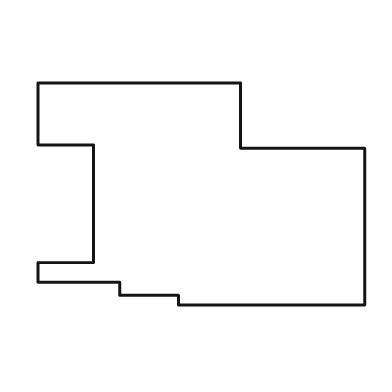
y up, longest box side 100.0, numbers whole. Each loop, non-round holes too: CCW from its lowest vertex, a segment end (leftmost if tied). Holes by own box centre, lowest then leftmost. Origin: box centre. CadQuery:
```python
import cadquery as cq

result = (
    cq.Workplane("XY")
    .moveTo(-7.0, -34.0)
    .lineTo(50.0, -34.0)
    .lineTo(50.0, 14.0)
    .lineTo(12.0, 14.0)
    .lineTo(12.0, 34.0)
    .lineTo(-50.0, 34.0)
    .lineTo(-50.0, 15.0)
    .lineTo(-33.0, 15.0)
    .lineTo(-33.0, -21.0)
    .lineTo(-50.0, -21.0)
    .lineTo(-50.0, -27.0)
    .lineTo(-25.0, -27.0)
    .lineTo(-25.0, -31.0)
    .lineTo(-7.0, -31.0)
    .close()
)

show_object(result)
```